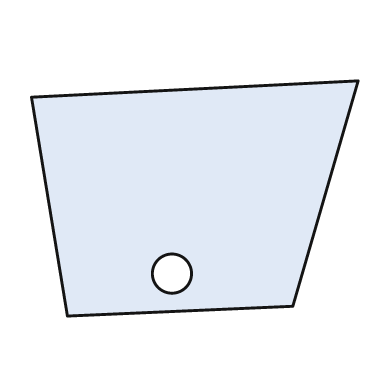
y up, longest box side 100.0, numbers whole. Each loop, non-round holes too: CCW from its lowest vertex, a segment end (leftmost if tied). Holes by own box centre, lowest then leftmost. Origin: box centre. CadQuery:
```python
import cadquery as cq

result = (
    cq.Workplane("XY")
    .moveTo(-39.0, -36.0)
    .lineTo(30.0, -33.0)
    .lineTo(50.0, 36.0)
    .lineTo(-50.0, 31.0)
    .close()
    .moveTo(-7.0, -23.0)
    .circle(6.0)
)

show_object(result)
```